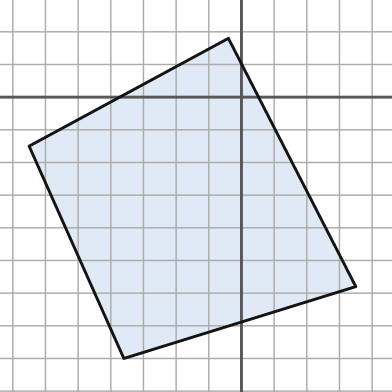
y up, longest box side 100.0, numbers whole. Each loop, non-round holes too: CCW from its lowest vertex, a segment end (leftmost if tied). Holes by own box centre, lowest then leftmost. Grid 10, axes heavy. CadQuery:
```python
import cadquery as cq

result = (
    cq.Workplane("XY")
    .moveTo(-36.0, -80.0)
    .lineTo(35.0, -58.0)
    .lineTo(-4.0, 18.0)
    .lineTo(-65.0, -15.0)
    .close()
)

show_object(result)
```